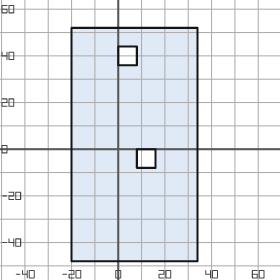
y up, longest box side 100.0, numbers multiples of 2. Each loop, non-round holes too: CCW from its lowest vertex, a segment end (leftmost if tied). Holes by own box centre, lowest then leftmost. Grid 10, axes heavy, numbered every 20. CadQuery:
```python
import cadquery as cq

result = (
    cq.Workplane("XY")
    .moveTo(-20.0, -48.0)
    .lineTo(34.0, -48.0)
    .lineTo(34.0, 52.0)
    .lineTo(-20.0, 52.0)
    .close()
    .moveTo(8.0, -8.0)
    .lineTo(16.0, -8.0)
    .lineTo(16.0, 0.0)
    .lineTo(8.0, 0.0)
    .close()
    .moveTo(0.0, 36.0)
    .lineTo(8.0, 36.0)
    .lineTo(8.0, 44.0)
    .lineTo(0.0, 44.0)
    .close()
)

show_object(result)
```